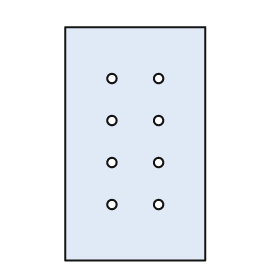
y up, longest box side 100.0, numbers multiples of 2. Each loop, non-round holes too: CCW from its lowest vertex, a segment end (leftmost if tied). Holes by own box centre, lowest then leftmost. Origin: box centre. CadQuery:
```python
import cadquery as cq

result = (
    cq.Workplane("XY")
    .moveTo(-30.0, -50.0)
    .lineTo(30.0, -50.0)
    .lineTo(30.0, 50.0)
    .lineTo(-30.0, 50.0)
    .close()
    .moveTo(-10.0, -26.0)
    .circle(2.0)
    .moveTo(10.0, -26.0)
    .circle(2.0)
    .moveTo(-10.0, -8.0)
    .circle(2.0)
    .moveTo(10.0, -8.0)
    .circle(2.0)
    .moveTo(-10.0, 10.0)
    .circle(2.0)
    .moveTo(10.0, 10.0)
    .circle(2.0)
    .moveTo(-10.0, 28.0)
    .circle(2.0)
    .moveTo(10.0, 28.0)
    .circle(2.0)
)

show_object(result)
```